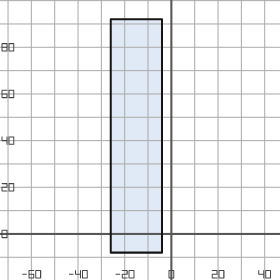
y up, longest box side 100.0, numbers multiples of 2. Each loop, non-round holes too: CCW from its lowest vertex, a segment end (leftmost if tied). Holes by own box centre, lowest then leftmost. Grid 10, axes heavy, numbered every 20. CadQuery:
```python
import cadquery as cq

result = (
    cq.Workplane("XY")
    .moveTo(-26.0, -8.0)
    .lineTo(-4.0, -8.0)
    .lineTo(-4.0, 92.0)
    .lineTo(-26.0, 92.0)
    .close()
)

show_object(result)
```